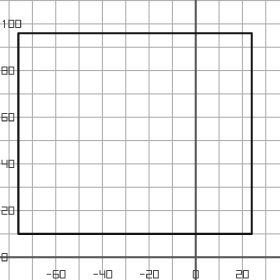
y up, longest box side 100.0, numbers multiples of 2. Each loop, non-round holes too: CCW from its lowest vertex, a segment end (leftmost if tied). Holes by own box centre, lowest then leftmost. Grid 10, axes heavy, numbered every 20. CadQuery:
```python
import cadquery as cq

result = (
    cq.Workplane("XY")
    .moveTo(-76.0, 10.0)
    .lineTo(24.0, 10.0)
    .lineTo(24.0, 96.0)
    .lineTo(-76.0, 96.0)
    .close()
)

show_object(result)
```